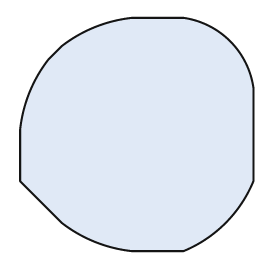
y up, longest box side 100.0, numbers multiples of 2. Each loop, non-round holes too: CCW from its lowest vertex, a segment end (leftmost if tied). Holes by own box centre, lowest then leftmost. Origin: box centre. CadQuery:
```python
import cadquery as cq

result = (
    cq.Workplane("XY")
    .moveTo(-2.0, -50.0)
    .lineTo(20.0, -50.0)
    .threePointArc((38.0, -38.0), (50.0, -20.0))
    .lineTo(50.0, 20.0)
    .threePointArc((40.0, 40.0), (20.0, 50.0))
    .lineTo(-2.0, 50.0)
    .threePointArc((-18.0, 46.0), (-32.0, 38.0))
    .lineTo(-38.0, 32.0)
    .threePointArc((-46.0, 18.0), (-50.0, 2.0))
    .lineTo(-50.0, -20.0)
    .lineTo(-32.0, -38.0)
    .threePointArc((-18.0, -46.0), (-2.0, -50.0))
    .close()
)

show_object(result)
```